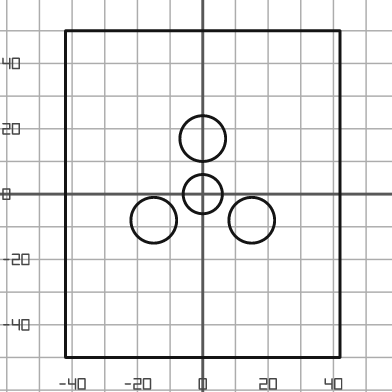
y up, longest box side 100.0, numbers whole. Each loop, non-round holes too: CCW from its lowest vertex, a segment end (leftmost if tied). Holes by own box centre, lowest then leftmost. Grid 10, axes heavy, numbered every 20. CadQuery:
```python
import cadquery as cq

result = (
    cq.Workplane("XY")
    .moveTo(-42.0, -50.0)
    .lineTo(42.0, -50.0)
    .lineTo(42.0, 50.0)
    .lineTo(-42.0, 50.0)
    .close()
    .moveTo(-15.0, -8.0)
    .circle(7.0)
    .moveTo(15.0, -8.0)
    .circle(7.0)
    .moveTo(0.0, 0.0)
    .circle(6.0)
    .moveTo(0.0, 17.0)
    .circle(7.0)
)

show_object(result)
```